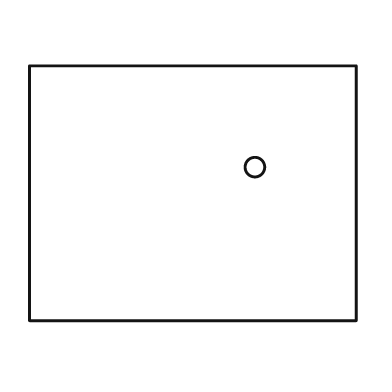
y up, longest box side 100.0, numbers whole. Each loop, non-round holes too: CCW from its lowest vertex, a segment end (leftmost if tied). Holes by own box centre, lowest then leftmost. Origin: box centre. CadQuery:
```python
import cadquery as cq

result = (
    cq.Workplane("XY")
    .moveTo(-50.0, -39.0)
    .lineTo(50.0, -39.0)
    .lineTo(50.0, 39.0)
    .lineTo(-50.0, 39.0)
    .close()
    .moveTo(19.0, 8.0)
    .circle(3.0)
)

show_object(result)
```